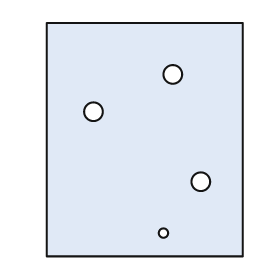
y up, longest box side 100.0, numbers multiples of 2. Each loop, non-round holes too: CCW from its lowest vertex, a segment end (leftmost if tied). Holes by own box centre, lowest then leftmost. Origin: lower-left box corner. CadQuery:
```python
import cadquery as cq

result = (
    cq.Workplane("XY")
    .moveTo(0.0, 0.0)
    .lineTo(84.0, 0.0)
    .lineTo(84.0, 100.0)
    .lineTo(0.0, 100.0)
    .close()
    .moveTo(50.0, 10.0)
    .circle(2.0)
    .moveTo(66.0, 32.0)
    .circle(4.0)
    .moveTo(20.0, 62.0)
    .circle(4.0)
    .moveTo(54.0, 78.0)
    .circle(4.0)
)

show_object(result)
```